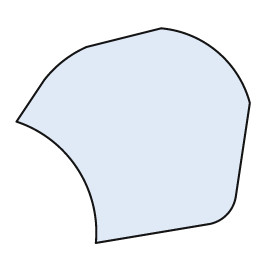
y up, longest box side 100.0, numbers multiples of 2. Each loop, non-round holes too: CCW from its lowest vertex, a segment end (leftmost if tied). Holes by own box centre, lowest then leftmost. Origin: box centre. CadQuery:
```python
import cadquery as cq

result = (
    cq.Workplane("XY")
    .moveTo(-16.0, -46.0)
    .lineTo(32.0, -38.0)
    .threePointArc((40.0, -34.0), (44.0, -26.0))
    .lineTo(50.0, 14.0)
    .threePointArc((36.0, 36.0), (12.0, 46.0))
    .lineTo(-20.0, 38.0)
    .threePointArc((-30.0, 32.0), (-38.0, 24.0))
    .lineTo(-50.0, 6.0)
    .threePointArc((-24.0, -14.0), (-16.0, -46.0))
    .close()
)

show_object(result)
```